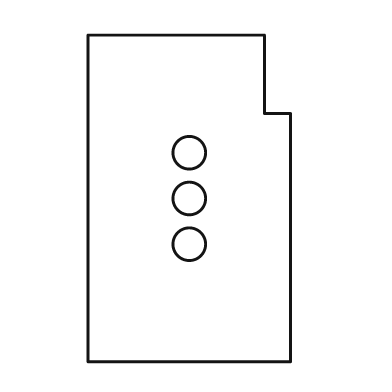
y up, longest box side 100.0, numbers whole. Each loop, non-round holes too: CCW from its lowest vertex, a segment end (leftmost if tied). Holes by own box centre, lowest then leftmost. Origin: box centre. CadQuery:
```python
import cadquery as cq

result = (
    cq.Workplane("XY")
    .moveTo(-31.0, -50.0)
    .lineTo(31.0, -50.0)
    .lineTo(31.0, 26.0)
    .lineTo(23.0, 26.0)
    .lineTo(23.0, 50.0)
    .lineTo(-31.0, 50.0)
    .close()
    .moveTo(0.0, -14.0)
    .circle(5.0)
    .moveTo(0.0, 0.0)
    .circle(5.0)
    .moveTo(0.0, 14.0)
    .circle(5.0)
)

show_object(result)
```